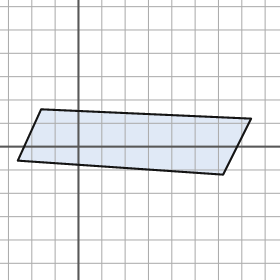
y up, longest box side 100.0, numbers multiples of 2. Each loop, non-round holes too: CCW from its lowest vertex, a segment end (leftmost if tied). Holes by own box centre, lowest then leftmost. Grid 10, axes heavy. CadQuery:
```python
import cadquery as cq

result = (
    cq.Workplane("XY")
    .moveTo(62.0, -12.0)
    .lineTo(74.0, 12.0)
    .lineTo(-16.0, 16.0)
    .lineTo(-26.0, -6.0)
    .close()
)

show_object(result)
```